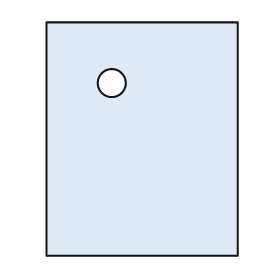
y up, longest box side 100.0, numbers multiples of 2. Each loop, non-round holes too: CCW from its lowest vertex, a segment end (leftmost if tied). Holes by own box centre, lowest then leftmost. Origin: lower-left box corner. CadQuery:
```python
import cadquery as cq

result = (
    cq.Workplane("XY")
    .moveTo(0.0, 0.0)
    .lineTo(82.0, 0.0)
    .lineTo(82.0, 100.0)
    .lineTo(0.0, 100.0)
    .close()
    .moveTo(28.0, 74.0)
    .circle(6.0)
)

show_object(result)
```